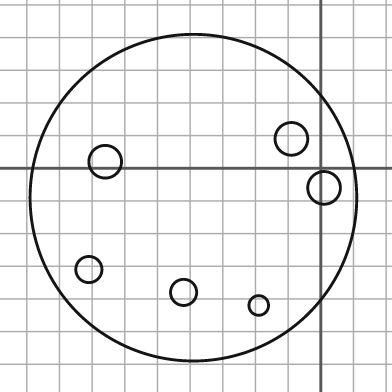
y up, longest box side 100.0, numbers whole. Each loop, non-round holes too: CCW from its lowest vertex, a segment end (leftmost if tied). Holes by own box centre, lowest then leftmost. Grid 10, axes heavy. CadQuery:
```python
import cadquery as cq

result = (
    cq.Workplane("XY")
    .moveTo(-39.0, -9.0)
    .circle(50.0)
    .moveTo(-19.0, -42.0)
    .circle(3.0)
    .moveTo(-42.0, -38.0)
    .circle(4.0)
    .moveTo(-71.0, -31.0)
    .circle(4.0)
    .moveTo(1.0, -6.0)
    .circle(5.0)
    .moveTo(-66.0, 2.0)
    .circle(5.0)
    .moveTo(-9.0, 9.0)
    .circle(5.0)
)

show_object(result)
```